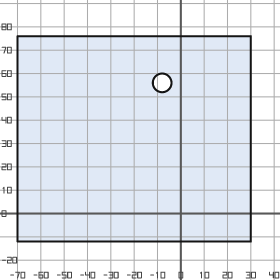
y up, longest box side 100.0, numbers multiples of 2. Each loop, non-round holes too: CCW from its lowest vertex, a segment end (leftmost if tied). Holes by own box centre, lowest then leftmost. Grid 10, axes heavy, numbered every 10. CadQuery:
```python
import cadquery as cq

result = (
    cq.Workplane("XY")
    .moveTo(-70.0, -12.0)
    .lineTo(30.0, -12.0)
    .lineTo(30.0, 76.0)
    .lineTo(-70.0, 76.0)
    .close()
    .moveTo(-8.0, 56.0)
    .circle(4.0)
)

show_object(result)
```